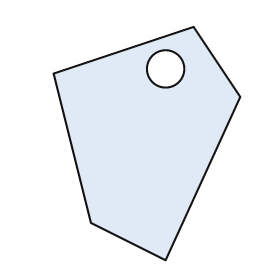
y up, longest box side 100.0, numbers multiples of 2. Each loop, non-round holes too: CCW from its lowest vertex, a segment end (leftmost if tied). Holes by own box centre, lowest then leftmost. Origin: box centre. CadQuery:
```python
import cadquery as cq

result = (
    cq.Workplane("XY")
    .moveTo(8.0, -50.0)
    .lineTo(40.0, 20.0)
    .lineTo(20.0, 50.0)
    .lineTo(-40.0, 30.0)
    .lineTo(-24.0, -34.0)
    .close()
    .moveTo(8.0, 32.0)
    .circle(8.0)
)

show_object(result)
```